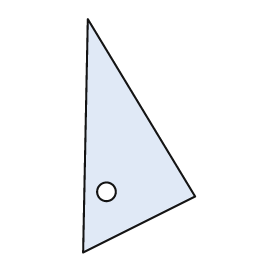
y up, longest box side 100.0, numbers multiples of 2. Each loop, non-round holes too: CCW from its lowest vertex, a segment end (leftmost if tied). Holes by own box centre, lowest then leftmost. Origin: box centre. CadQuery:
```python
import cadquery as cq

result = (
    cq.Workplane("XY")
    .moveTo(-24.0, -50.0)
    .lineTo(24.0, -26.0)
    .lineTo(-22.0, 50.0)
    .close()
    .moveTo(-14.0, -24.0)
    .circle(4.0)
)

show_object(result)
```